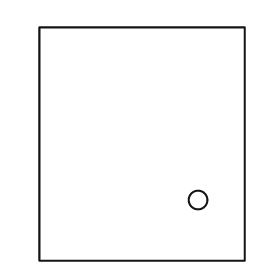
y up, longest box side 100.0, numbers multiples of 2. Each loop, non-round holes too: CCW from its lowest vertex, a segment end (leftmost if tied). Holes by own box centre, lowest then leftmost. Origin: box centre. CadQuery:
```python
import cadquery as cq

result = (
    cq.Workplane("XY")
    .moveTo(-44.0, -50.0)
    .lineTo(44.0, -50.0)
    .lineTo(44.0, 50.0)
    .lineTo(-44.0, 50.0)
    .close()
    .moveTo(24.0, -24.0)
    .circle(4.0)
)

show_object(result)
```